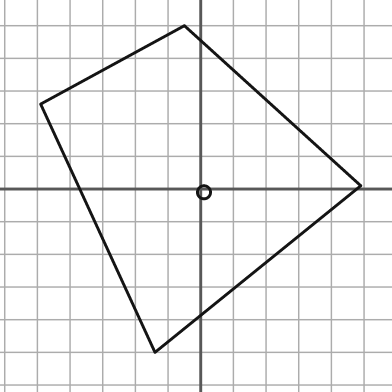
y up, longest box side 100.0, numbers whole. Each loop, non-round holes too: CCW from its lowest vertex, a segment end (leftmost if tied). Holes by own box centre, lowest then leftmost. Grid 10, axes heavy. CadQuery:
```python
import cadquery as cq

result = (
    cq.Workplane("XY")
    .moveTo(-14.0, -50.0)
    .lineTo(49.0, 1.0)
    .lineTo(-5.0, 50.0)
    .lineTo(-49.0, 26.0)
    .close()
    .moveTo(1.0, -1.0)
    .circle(2.0)
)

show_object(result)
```